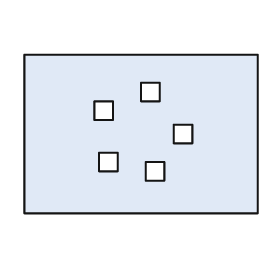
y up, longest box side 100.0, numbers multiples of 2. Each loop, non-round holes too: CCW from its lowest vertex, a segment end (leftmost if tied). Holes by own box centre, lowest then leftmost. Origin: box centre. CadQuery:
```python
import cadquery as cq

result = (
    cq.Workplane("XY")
    .moveTo(-50.0, -34.0)
    .lineTo(50.0, -34.0)
    .lineTo(50.0, 34.0)
    .lineTo(-50.0, 34.0)
    .close()
    .moveTo(2.0, -20.0)
    .lineTo(10.0, -20.0)
    .lineTo(10.0, -12.0)
    .lineTo(2.0, -12.0)
    .close()
    .moveTo(-18.0, -16.0)
    .lineTo(-10.0, -16.0)
    .lineTo(-10.0, -8.0)
    .lineTo(-18.0, -8.0)
    .close()
    .moveTo(14.0, -4.0)
    .lineTo(22.0, -4.0)
    .lineTo(22.0, 4.0)
    .lineTo(14.0, 4.0)
    .close()
    .moveTo(-20.0, 6.0)
    .lineTo(-12.0, 6.0)
    .lineTo(-12.0, 14.0)
    .lineTo(-20.0, 14.0)
    .close()
    .moveTo(0.0, 14.0)
    .lineTo(8.0, 14.0)
    .lineTo(8.0, 22.0)
    .lineTo(0.0, 22.0)
    .close()
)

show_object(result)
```